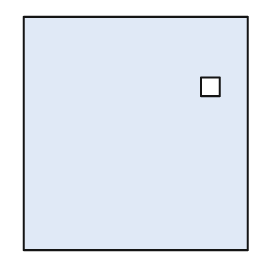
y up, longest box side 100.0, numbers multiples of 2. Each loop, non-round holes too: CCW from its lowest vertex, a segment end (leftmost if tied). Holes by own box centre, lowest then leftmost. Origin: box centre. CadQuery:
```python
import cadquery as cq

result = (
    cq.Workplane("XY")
    .moveTo(-48.0, -50.0)
    .lineTo(48.0, -50.0)
    .lineTo(48.0, 50.0)
    .lineTo(-48.0, 50.0)
    .close()
    .moveTo(28.0, 16.0)
    .lineTo(36.0, 16.0)
    .lineTo(36.0, 24.0)
    .lineTo(28.0, 24.0)
    .close()
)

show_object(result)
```